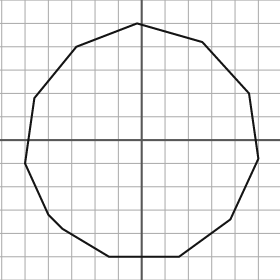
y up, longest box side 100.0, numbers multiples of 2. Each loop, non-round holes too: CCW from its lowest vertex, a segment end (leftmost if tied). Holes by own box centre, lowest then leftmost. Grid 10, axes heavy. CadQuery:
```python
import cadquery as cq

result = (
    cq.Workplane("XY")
    .moveTo(-14.0, -50.0)
    .lineTo(16.0, -50.0)
    .lineTo(38.0, -34.0)
    .lineTo(50.0, -8.0)
    .lineTo(46.0, 20.0)
    .lineTo(26.0, 42.0)
    .lineTo(-2.0, 50.0)
    .lineTo(-28.0, 40.0)
    .lineTo(-46.0, 18.0)
    .lineTo(-50.0, -10.0)
    .lineTo(-40.0, -32.0)
    .lineTo(-34.0, -38.0)
    .close()
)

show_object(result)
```